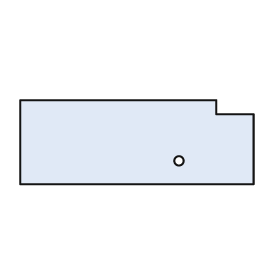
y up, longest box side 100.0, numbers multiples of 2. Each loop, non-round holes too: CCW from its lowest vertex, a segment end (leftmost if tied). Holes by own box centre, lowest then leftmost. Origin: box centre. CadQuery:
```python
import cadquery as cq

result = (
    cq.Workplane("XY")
    .moveTo(-50.0, -18.0)
    .lineTo(50.0, -18.0)
    .lineTo(50.0, 12.0)
    .lineTo(34.0, 12.0)
    .lineTo(34.0, 18.0)
    .lineTo(-50.0, 18.0)
    .close()
    .moveTo(18.0, -8.0)
    .circle(2.0)
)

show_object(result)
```